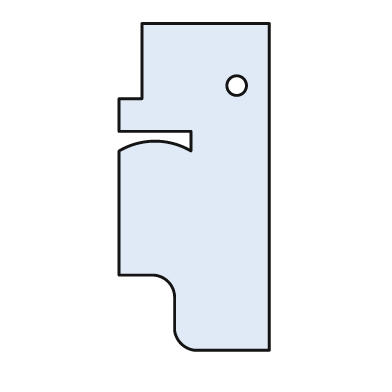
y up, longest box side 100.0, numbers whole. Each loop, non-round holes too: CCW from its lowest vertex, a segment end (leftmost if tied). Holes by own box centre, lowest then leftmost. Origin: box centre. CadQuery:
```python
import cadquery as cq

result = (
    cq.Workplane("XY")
    .moveTo(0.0, -50.0)
    .lineTo(23.0, -50.0)
    .lineTo(23.0, 50.0)
    .lineTo(-16.0, 50.0)
    .lineTo(-16.0, 27.0)
    .lineTo(-23.0, 27.0)
    .lineTo(-23.0, 17.0)
    .lineTo(-1.0, 17.0)
    .lineTo(-1.0, 11.0)
    .threePointArc((-12.0, 14.0), (-23.0, 11.0))
    .lineTo(-23.0, -27.0)
    .lineTo(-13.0, -27.0)
    .threePointArc((-8.0, -29.0), (-6.0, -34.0))
    .lineTo(-6.0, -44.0)
    .threePointArc((-4.0, -48.0), (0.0, -50.0))
    .close()
    .moveTo(13.0, 31.0)
    .circle(3.0)
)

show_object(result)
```